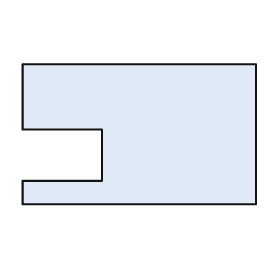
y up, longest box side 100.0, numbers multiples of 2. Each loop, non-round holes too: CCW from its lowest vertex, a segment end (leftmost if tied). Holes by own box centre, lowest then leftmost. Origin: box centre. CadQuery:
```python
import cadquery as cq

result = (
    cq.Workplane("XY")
    .moveTo(-50.0, -30.0)
    .lineTo(50.0, -30.0)
    .lineTo(50.0, 30.0)
    .lineTo(-50.0, 30.0)
    .lineTo(-50.0, 2.0)
    .lineTo(-16.0, 2.0)
    .lineTo(-16.0, -20.0)
    .lineTo(-50.0, -20.0)
    .close()
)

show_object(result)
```